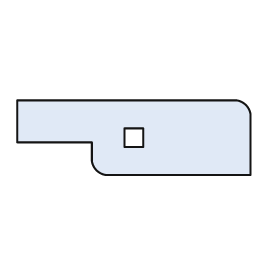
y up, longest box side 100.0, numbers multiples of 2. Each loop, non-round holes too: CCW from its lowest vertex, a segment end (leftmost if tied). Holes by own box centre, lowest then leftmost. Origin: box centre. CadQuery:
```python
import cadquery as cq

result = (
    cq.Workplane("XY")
    .moveTo(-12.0, -16.0)
    .lineTo(50.0, -16.0)
    .lineTo(50.0, 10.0)
    .threePointArc((48.0, 14.0), (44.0, 16.0))
    .lineTo(-50.0, 16.0)
    .lineTo(-50.0, -2.0)
    .lineTo(-18.0, -2.0)
    .lineTo(-18.0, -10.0)
    .threePointArc((-16.0, -14.0), (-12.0, -16.0))
    .close()
    .moveTo(-4.0, -4.0)
    .lineTo(4.0, -4.0)
    .lineTo(4.0, 4.0)
    .lineTo(-4.0, 4.0)
    .close()
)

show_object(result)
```